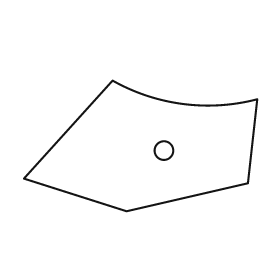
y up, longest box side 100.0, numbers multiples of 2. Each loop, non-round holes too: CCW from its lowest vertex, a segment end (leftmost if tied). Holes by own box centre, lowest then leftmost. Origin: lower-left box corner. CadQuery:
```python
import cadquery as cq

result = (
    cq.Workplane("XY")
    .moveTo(44.0, 0.0)
    .lineTo(96.0, 12.0)
    .lineTo(100.0, 48.0)
    .threePointArc((68.0, 46.0), (38.0, 56.0))
    .lineTo(0.0, 14.0)
    .close()
    .moveTo(60.0, 26.0)
    .circle(4.0)
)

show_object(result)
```